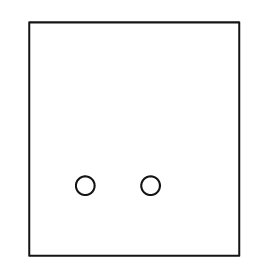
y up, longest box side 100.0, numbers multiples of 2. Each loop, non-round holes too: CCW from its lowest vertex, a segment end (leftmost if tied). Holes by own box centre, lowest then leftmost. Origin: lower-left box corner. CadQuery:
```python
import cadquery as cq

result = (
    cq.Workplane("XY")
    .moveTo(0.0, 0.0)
    .lineTo(90.0, 0.0)
    .lineTo(90.0, 100.0)
    .lineTo(0.0, 100.0)
    .close()
    .moveTo(24.0, 30.0)
    .circle(4.0)
    .moveTo(52.0, 30.0)
    .circle(4.0)
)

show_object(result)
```